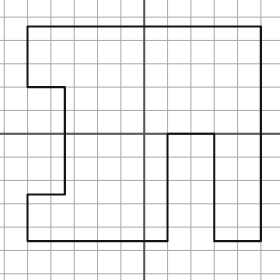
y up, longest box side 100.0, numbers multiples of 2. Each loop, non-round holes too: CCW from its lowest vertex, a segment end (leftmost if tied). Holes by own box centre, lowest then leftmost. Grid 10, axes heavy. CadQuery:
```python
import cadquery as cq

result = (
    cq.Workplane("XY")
    .moveTo(-50.0, -46.0)
    .lineTo(10.0, -46.0)
    .lineTo(10.0, 0.0)
    .lineTo(30.0, 0.0)
    .lineTo(30.0, -46.0)
    .lineTo(50.0, -46.0)
    .lineTo(50.0, 46.0)
    .lineTo(-50.0, 46.0)
    .lineTo(-50.0, 20.0)
    .lineTo(-34.0, 20.0)
    .lineTo(-34.0, -26.0)
    .lineTo(-50.0, -26.0)
    .close()
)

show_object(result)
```